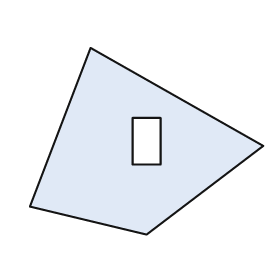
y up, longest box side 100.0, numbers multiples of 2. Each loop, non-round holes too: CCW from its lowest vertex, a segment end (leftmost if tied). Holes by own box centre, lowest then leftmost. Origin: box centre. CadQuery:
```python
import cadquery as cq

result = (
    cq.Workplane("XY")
    .moveTo(0.0, -40.0)
    .lineTo(50.0, -2.0)
    .lineTo(-24.0, 40.0)
    .lineTo(-50.0, -28.0)
    .close()
    .moveTo(-6.0, -10.0)
    .lineTo(6.0, -10.0)
    .lineTo(6.0, 10.0)
    .lineTo(-6.0, 10.0)
    .close()
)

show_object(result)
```